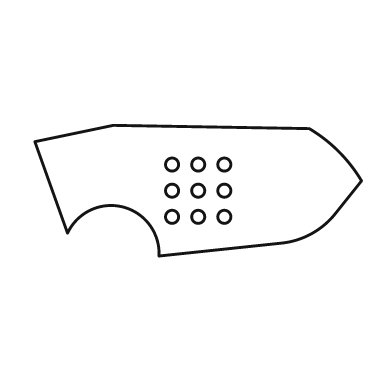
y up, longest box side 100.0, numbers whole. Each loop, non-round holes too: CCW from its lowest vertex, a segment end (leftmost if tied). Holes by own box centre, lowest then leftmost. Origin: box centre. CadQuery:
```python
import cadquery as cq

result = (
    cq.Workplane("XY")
    .moveTo(-12.0, -20.0)
    .lineTo(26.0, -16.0)
    .threePointArc((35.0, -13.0), (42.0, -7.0))
    .lineTo(50.0, 3.0)
    .threePointArc((43.0, 12.0), (34.0, 19.0))
    .lineTo(-26.0, 20.0)
    .lineTo(-50.0, 15.0)
    .lineTo(-40.0, -13.0)
    .threePointArc((-23.0, -5.0), (-12.0, -20.0))
    .close()
    .moveTo(-8.0, -8.0)
    .circle(2.0)
    .moveTo(0.0, -8.0)
    .circle(2.0)
    .moveTo(8.0, -8.0)
    .circle(2.0)
    .moveTo(-8.0, 0.0)
    .circle(2.0)
    .moveTo(0.0, 0.0)
    .circle(2.0)
    .moveTo(8.0, 0.0)
    .circle(2.0)
    .moveTo(-8.0, 8.0)
    .circle(2.0)
    .moveTo(0.0, 8.0)
    .circle(2.0)
    .moveTo(8.0, 8.0)
    .circle(2.0)
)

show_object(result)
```